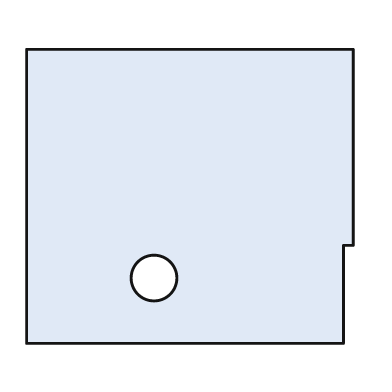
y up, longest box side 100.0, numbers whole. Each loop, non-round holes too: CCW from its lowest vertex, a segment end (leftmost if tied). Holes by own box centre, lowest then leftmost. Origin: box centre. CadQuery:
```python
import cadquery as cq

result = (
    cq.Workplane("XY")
    .moveTo(-50.0, -45.0)
    .lineTo(47.0, -45.0)
    .lineTo(47.0, -15.0)
    .lineTo(50.0, -15.0)
    .lineTo(50.0, 45.0)
    .lineTo(-50.0, 45.0)
    .close()
    .moveTo(-11.0, -25.0)
    .circle(7.0)
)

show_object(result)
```